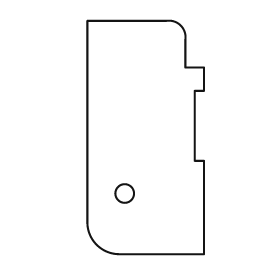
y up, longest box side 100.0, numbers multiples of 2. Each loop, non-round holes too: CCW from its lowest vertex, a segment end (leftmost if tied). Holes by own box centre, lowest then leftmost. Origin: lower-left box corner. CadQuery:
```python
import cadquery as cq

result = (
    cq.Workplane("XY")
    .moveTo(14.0, 0.0)
    .lineTo(50.0, 0.0)
    .lineTo(50.0, 40.0)
    .lineTo(46.0, 40.0)
    .lineTo(46.0, 70.0)
    .lineTo(50.0, 70.0)
    .lineTo(50.0, 80.0)
    .lineTo(42.0, 80.0)
    .lineTo(42.0, 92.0)
    .threePointArc((40.0, 98.0), (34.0, 100.0))
    .lineTo(0.0, 100.0)
    .lineTo(0.0, 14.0)
    .threePointArc((4.0, 4.0), (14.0, 0.0))
    .close()
    .moveTo(16.0, 26.0)
    .circle(4.0)
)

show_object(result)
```